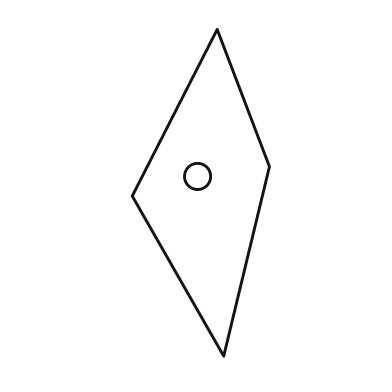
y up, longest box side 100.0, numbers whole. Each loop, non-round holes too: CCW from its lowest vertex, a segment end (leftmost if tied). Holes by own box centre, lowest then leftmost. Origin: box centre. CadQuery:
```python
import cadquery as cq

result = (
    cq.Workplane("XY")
    .moveTo(7.0, -50.0)
    .lineTo(21.0, 8.0)
    .lineTo(5.0, 50.0)
    .lineTo(-21.0, -1.0)
    .close()
    .moveTo(-1.0, 5.0)
    .circle(4.0)
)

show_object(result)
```